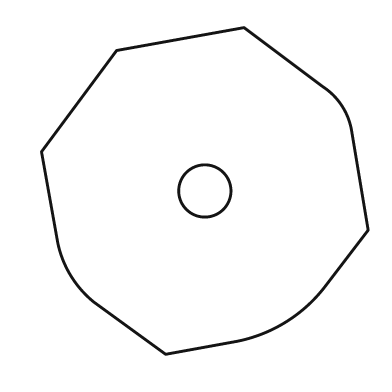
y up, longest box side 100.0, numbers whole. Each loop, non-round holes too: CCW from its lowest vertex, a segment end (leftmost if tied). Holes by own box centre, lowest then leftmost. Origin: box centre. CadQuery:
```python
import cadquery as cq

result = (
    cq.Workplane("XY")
    .moveTo(-12.0, -50.0)
    .lineTo(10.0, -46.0)
    .threePointArc((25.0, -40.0), (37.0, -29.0))
    .lineTo(50.0, -12.0)
    .lineTo(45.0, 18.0)
    .threePointArc((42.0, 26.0), (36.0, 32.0))
    .lineTo(12.0, 50.0)
    .lineTo(-27.0, 43.0)
    .lineTo(-50.0, 12.0)
    .lineTo(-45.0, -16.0)
    .threePointArc((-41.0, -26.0), (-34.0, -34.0))
    .close()
    .moveTo(0.0, 0.0)
    .circle(8.0)
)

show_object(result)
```